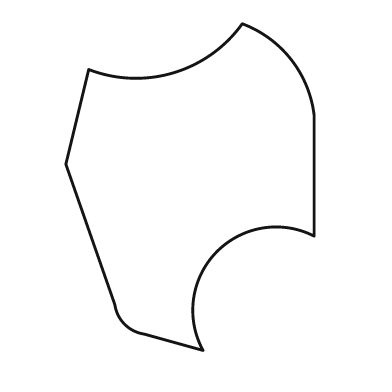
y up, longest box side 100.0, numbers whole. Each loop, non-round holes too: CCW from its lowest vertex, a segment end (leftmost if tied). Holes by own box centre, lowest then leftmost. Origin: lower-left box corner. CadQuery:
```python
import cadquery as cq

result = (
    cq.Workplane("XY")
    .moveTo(42.0, 0.0)
    .threePointArc((46.0, 30.0), (76.0, 35.0))
    .lineTo(76.0, 72.0)
    .threePointArc((69.0, 89.0), (54.0, 100.0))
    .threePointArc((33.0, 85.0), (7.0, 86.0))
    .lineTo(0.0, 57.0)
    .lineTo(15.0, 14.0)
    .threePointArc((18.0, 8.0), (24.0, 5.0))
    .close()
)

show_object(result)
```